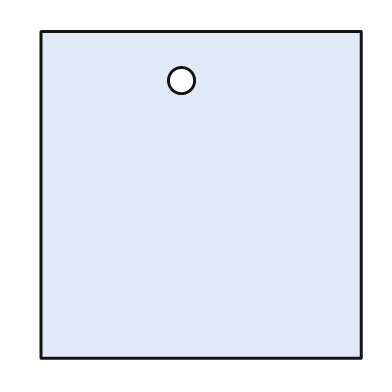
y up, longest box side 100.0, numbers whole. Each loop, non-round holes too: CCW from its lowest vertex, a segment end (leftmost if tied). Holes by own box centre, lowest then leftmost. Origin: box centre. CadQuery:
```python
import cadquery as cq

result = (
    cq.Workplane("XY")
    .moveTo(-49.0, -50.0)
    .lineTo(49.0, -50.0)
    .lineTo(49.0, 50.0)
    .lineTo(-49.0, 50.0)
    .close()
    .moveTo(-6.0, 35.0)
    .circle(4.0)
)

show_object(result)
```